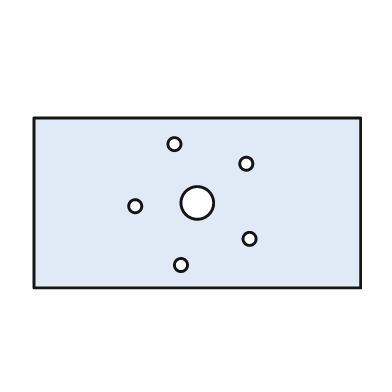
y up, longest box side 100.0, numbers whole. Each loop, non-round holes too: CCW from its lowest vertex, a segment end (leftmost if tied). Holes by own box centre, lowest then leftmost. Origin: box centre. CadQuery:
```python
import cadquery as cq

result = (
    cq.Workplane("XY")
    .moveTo(-50.0, -26.0)
    .lineTo(50.0, -26.0)
    .lineTo(50.0, 26.0)
    .lineTo(-50.0, 26.0)
    .close()
    .moveTo(-5.0, -19.0)
    .circle(2.0)
    .moveTo(16.0, -11.0)
    .circle(2.0)
    .moveTo(-19.0, -1.0)
    .circle(2.0)
    .moveTo(0.0, 0.0)
    .circle(5.0)
    .moveTo(15.0, 12.0)
    .circle(2.0)
    .moveTo(-7.0, 18.0)
    .circle(2.0)
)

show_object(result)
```